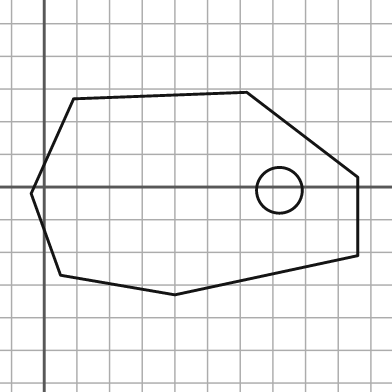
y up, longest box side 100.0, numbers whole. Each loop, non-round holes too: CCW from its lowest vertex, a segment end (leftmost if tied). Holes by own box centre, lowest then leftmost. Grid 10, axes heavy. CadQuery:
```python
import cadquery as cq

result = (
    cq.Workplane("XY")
    .moveTo(40.0, -33.0)
    .lineTo(96.0, -21.0)
    .lineTo(96.0, 3.0)
    .lineTo(62.0, 29.0)
    .lineTo(9.0, 27.0)
    .lineTo(-4.0, -2.0)
    .lineTo(5.0, -27.0)
    .close()
    .moveTo(72.0, -1.0)
    .circle(7.0)
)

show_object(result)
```